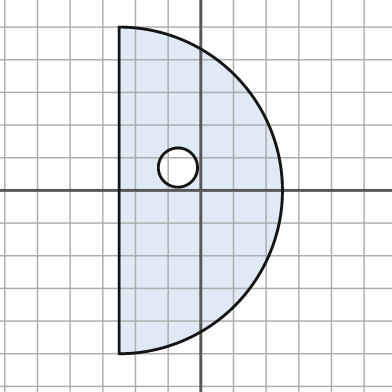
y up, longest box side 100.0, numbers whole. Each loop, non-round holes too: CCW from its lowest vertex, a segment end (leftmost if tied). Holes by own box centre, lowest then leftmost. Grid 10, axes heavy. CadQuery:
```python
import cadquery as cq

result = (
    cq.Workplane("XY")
    .moveTo(-25.0, -50.0)
    .threePointArc((25.0, 0.0), (-25.0, 50.0))
    .close()
    .moveTo(-7.0, 7.0)
    .circle(6.0)
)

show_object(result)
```